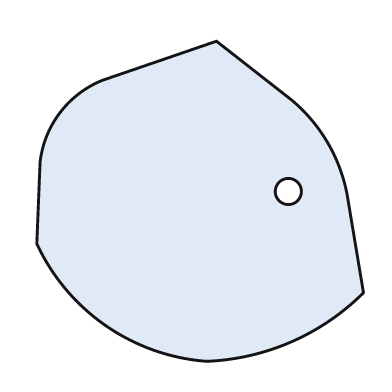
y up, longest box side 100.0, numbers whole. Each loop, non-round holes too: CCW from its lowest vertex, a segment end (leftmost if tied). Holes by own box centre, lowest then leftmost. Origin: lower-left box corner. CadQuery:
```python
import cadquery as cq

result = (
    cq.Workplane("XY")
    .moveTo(52.0, 0.0)
    .threePointArc((78.0, 6.0), (100.0, 21.0))
    .lineTo(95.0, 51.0)
    .threePointArc((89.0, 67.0), (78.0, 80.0))
    .lineTo(55.0, 98.0)
    .lineTo(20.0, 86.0)
    .threePointArc((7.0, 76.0), (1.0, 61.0))
    .lineTo(0.0, 36.0)
    .threePointArc((21.0, 11.0), (52.0, 0.0))
    .close()
    .moveTo(77.0, 52.0)
    .circle(4.0)
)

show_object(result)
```